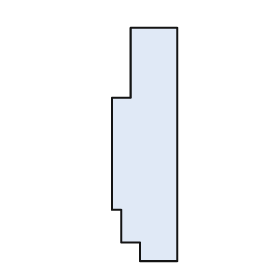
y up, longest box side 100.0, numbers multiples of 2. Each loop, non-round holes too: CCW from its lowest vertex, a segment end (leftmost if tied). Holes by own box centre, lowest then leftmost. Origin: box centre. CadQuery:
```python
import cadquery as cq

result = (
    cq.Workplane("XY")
    .moveTo(-2.0, -50.0)
    .lineTo(14.0, -50.0)
    .lineTo(14.0, 50.0)
    .lineTo(-6.0, 50.0)
    .lineTo(-6.0, 20.0)
    .lineTo(-14.0, 20.0)
    .lineTo(-14.0, -28.0)
    .lineTo(-10.0, -28.0)
    .lineTo(-10.0, -42.0)
    .lineTo(-2.0, -42.0)
    .close()
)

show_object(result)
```